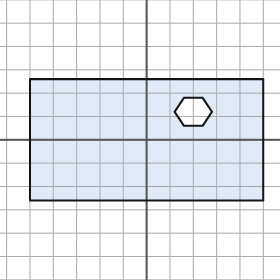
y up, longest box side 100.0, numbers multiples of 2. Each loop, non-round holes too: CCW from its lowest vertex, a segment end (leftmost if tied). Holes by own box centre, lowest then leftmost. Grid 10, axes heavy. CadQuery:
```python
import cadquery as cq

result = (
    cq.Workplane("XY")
    .moveTo(-50.0, -26.0)
    .lineTo(50.0, -26.0)
    .lineTo(50.0, 26.0)
    .lineTo(-50.0, 26.0)
    .close()
    .moveTo(16.0, 6.0)
    .lineTo(24.0, 6.0)
    .lineTo(28.0, 12.0)
    .lineTo(24.0, 18.0)
    .lineTo(16.0, 18.0)
    .lineTo(12.0, 12.0)
    .close()
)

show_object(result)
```